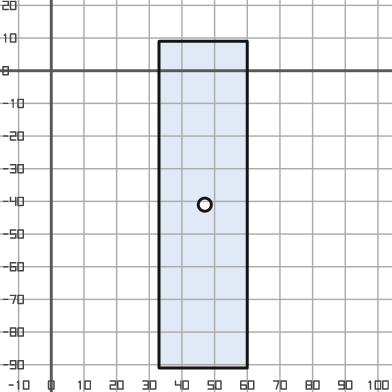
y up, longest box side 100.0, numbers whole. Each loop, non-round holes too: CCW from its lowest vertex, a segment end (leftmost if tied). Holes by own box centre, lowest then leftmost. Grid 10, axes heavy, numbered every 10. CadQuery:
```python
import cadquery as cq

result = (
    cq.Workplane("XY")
    .moveTo(33.0, -91.0)
    .lineTo(60.0, -91.0)
    .lineTo(60.0, 9.0)
    .lineTo(33.0, 9.0)
    .close()
    .moveTo(47.0, -41.0)
    .circle(2.0)
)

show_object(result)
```